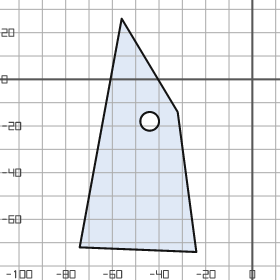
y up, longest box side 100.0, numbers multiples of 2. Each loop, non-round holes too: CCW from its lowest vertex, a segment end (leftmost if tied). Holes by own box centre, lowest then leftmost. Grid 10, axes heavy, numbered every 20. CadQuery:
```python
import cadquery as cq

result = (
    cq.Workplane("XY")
    .moveTo(-24.0, -74.0)
    .lineTo(-32.0, -14.0)
    .lineTo(-56.0, 26.0)
    .lineTo(-74.0, -72.0)
    .close()
    .moveTo(-44.0, -18.0)
    .circle(4.0)
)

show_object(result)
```